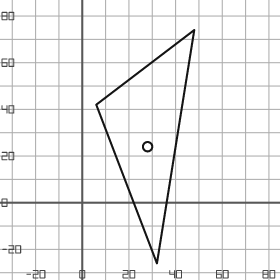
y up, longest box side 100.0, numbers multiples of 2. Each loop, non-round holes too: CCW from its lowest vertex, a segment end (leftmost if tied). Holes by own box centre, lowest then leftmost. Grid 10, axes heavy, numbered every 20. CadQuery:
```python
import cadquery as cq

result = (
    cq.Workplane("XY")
    .moveTo(32.0, -26.0)
    .lineTo(48.0, 74.0)
    .lineTo(6.0, 42.0)
    .close()
    .moveTo(28.0, 24.0)
    .circle(2.0)
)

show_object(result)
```